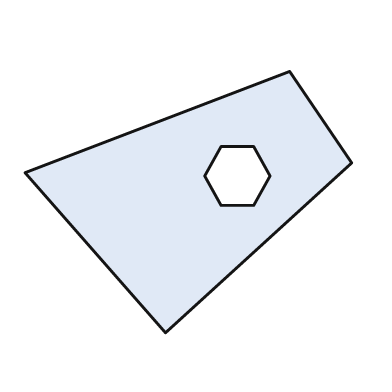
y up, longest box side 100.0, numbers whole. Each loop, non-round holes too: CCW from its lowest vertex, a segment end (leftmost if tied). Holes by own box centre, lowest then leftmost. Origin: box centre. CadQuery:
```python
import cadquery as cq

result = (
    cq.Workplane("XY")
    .moveTo(-7.0, -40.0)
    .lineTo(50.0, 12.0)
    .lineTo(31.0, 40.0)
    .lineTo(-50.0, 9.0)
    .close()
    .moveTo(10.0, -1.0)
    .lineTo(20.0, -1.0)
    .lineTo(25.0, 8.0)
    .lineTo(20.0, 17.0)
    .lineTo(10.0, 17.0)
    .lineTo(5.0, 8.0)
    .close()
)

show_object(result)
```